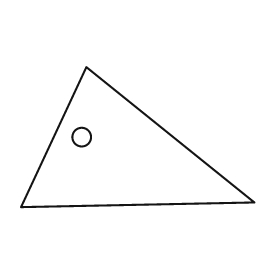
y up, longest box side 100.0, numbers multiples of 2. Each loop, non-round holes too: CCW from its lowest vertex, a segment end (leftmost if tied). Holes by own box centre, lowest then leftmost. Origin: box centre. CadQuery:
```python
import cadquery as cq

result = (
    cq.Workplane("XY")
    .moveTo(-50.0, -30.0)
    .lineTo(50.0, -28.0)
    .lineTo(-22.0, 30.0)
    .close()
    .moveTo(-24.0, 0.0)
    .circle(4.0)
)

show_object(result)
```